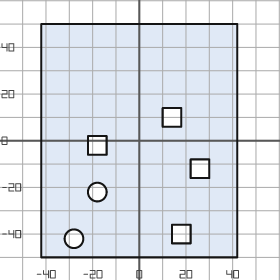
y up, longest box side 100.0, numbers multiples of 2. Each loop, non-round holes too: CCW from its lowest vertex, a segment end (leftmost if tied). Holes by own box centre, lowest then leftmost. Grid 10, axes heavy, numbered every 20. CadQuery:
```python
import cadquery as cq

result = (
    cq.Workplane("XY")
    .moveTo(-42.0, -50.0)
    .lineTo(42.0, -50.0)
    .lineTo(42.0, 50.0)
    .lineTo(-42.0, 50.0)
    .close()
    .moveTo(-28.0, -42.0)
    .circle(4.0)
    .moveTo(14.0, -44.0)
    .lineTo(22.0, -44.0)
    .lineTo(22.0, -36.0)
    .lineTo(14.0, -36.0)
    .close()
    .moveTo(-18.0, -22.0)
    .circle(4.0)
    .moveTo(22.0, -16.0)
    .lineTo(30.0, -16.0)
    .lineTo(30.0, -8.0)
    .lineTo(22.0, -8.0)
    .close()
    .moveTo(-22.0, -6.0)
    .lineTo(-14.0, -6.0)
    .lineTo(-14.0, 2.0)
    .lineTo(-22.0, 2.0)
    .close()
    .moveTo(10.0, 6.0)
    .lineTo(18.0, 6.0)
    .lineTo(18.0, 14.0)
    .lineTo(10.0, 14.0)
    .close()
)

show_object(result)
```